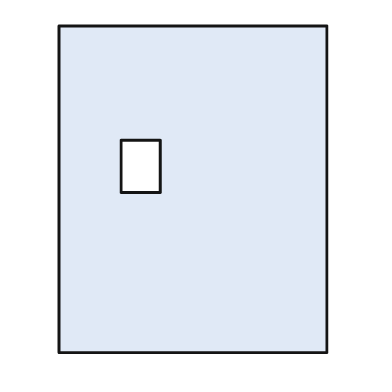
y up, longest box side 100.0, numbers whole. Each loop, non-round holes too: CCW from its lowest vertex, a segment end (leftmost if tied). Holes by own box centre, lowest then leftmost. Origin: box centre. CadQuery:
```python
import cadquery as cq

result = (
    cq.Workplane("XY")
    .moveTo(-41.0, -50.0)
    .lineTo(41.0, -50.0)
    .lineTo(41.0, 50.0)
    .lineTo(-41.0, 50.0)
    .close()
    .moveTo(-22.0, -1.0)
    .lineTo(-10.0, -1.0)
    .lineTo(-10.0, 15.0)
    .lineTo(-22.0, 15.0)
    .close()
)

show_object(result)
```